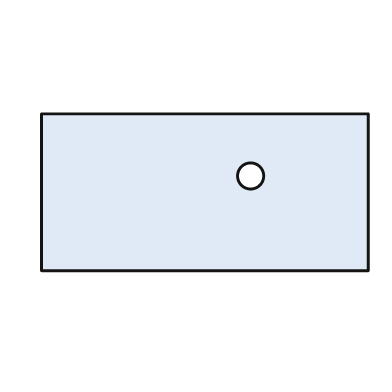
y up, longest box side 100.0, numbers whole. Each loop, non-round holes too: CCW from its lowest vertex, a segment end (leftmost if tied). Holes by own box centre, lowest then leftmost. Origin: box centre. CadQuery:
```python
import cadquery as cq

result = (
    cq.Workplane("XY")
    .moveTo(-50.0, -24.0)
    .lineTo(50.0, -24.0)
    .lineTo(50.0, 24.0)
    .lineTo(-50.0, 24.0)
    .close()
    .moveTo(14.0, 5.0)
    .circle(4.0)
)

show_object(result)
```